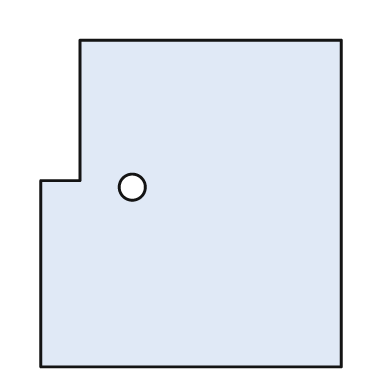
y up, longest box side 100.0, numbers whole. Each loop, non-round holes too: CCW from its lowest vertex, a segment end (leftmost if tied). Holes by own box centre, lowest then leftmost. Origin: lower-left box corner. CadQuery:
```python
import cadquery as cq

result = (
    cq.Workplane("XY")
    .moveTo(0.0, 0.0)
    .lineTo(92.0, 0.0)
    .lineTo(92.0, 100.0)
    .lineTo(12.0, 100.0)
    .lineTo(12.0, 57.0)
    .lineTo(0.0, 57.0)
    .close()
    .moveTo(28.0, 55.0)
    .circle(4.0)
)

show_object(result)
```